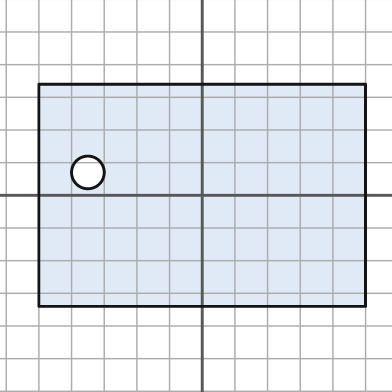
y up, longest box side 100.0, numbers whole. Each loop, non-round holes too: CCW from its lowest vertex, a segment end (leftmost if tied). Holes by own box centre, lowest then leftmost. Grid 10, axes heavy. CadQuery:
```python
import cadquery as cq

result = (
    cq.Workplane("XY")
    .moveTo(-50.0, -34.0)
    .lineTo(50.0, -34.0)
    .lineTo(50.0, 34.0)
    .lineTo(-50.0, 34.0)
    .close()
    .moveTo(-35.0, 7.0)
    .circle(5.0)
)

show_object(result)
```